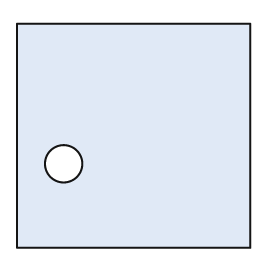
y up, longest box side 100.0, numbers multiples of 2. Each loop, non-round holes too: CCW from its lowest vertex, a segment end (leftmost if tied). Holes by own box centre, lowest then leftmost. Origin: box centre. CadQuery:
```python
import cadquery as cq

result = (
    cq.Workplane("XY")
    .moveTo(-50.0, -48.0)
    .lineTo(50.0, -48.0)
    .lineTo(50.0, 48.0)
    .lineTo(-50.0, 48.0)
    .close()
    .moveTo(-30.0, -12.0)
    .circle(8.0)
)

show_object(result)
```